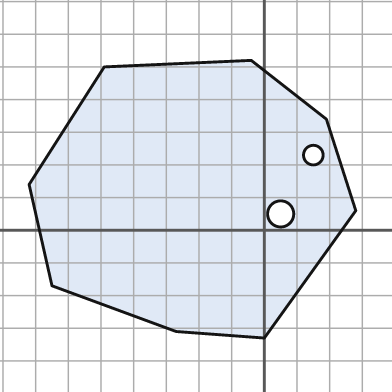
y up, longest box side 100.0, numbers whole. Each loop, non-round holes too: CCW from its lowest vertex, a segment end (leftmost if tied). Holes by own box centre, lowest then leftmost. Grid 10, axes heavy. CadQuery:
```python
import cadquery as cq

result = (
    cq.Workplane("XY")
    .moveTo(0.0, -33.0)
    .lineTo(28.0, 6.0)
    .lineTo(19.0, 34.0)
    .lineTo(-4.0, 52.0)
    .lineTo(-49.0, 50.0)
    .lineTo(-72.0, 14.0)
    .lineTo(-65.0, -17.0)
    .lineTo(-27.0, -31.0)
    .close()
    .moveTo(5.0, 5.0)
    .circle(4.0)
    .moveTo(15.0, 23.0)
    .circle(3.0)
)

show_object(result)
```